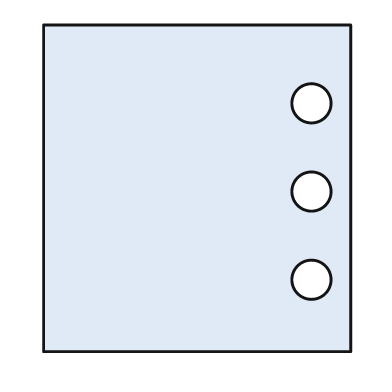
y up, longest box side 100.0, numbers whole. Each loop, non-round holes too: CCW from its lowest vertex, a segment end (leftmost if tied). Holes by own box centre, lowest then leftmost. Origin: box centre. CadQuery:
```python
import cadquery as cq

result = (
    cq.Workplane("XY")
    .moveTo(-47.0, -50.0)
    .lineTo(47.0, -50.0)
    .lineTo(47.0, 50.0)
    .lineTo(-47.0, 50.0)
    .close()
    .moveTo(35.0, -28.0)
    .circle(6.0)
    .moveTo(35.0, -1.0)
    .circle(6.0)
    .moveTo(35.0, 26.0)
    .circle(6.0)
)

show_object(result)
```